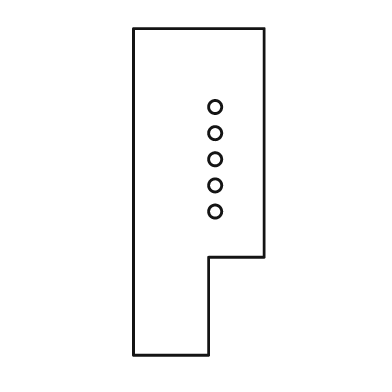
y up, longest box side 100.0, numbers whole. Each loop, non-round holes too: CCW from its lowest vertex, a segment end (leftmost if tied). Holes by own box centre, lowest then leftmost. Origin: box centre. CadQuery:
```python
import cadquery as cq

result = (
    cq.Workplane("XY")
    .moveTo(-20.0, -50.0)
    .lineTo(3.0, -50.0)
    .lineTo(3.0, -20.0)
    .lineTo(20.0, -20.0)
    .lineTo(20.0, 50.0)
    .lineTo(-20.0, 50.0)
    .close()
    .moveTo(5.0, -6.0)
    .circle(2.0)
    .moveTo(5.0, 2.0)
    .circle(2.0)
    .moveTo(5.0, 10.0)
    .circle(2.0)
    .moveTo(5.0, 18.0)
    .circle(2.0)
    .moveTo(5.0, 26.0)
    .circle(2.0)
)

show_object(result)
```